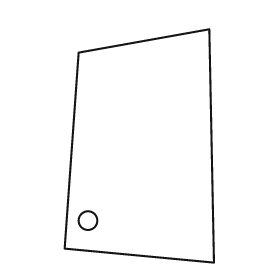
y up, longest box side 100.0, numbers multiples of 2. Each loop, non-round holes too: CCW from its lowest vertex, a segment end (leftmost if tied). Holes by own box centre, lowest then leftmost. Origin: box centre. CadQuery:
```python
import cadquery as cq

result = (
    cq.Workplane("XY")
    .moveTo(32.0, -50.0)
    .lineTo(30.0, 50.0)
    .lineTo(-26.0, 40.0)
    .lineTo(-32.0, -44.0)
    .close()
    .moveTo(-22.0, -32.0)
    .circle(4.0)
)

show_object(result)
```